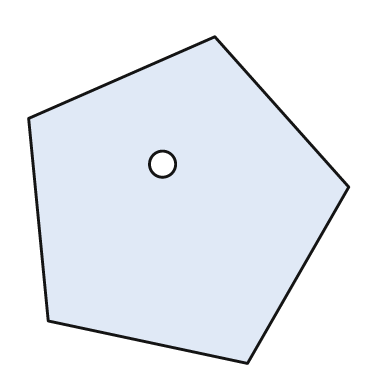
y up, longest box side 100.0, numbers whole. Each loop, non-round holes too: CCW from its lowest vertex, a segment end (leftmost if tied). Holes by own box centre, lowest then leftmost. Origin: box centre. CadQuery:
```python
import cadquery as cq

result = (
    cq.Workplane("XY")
    .moveTo(18.0, -50.0)
    .lineTo(49.0, 4.0)
    .lineTo(8.0, 50.0)
    .lineTo(-49.0, 25.0)
    .lineTo(-43.0, -37.0)
    .close()
    .moveTo(-8.0, 11.0)
    .circle(4.0)
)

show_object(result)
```